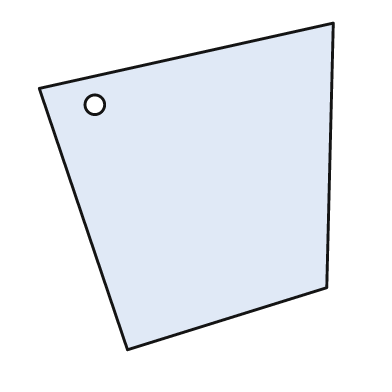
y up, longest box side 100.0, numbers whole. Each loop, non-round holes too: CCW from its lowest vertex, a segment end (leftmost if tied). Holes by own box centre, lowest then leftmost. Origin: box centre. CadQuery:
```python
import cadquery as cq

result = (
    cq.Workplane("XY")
    .moveTo(-18.0, -50.0)
    .lineTo(43.0, -31.0)
    .lineTo(45.0, 50.0)
    .lineTo(-45.0, 30.0)
    .close()
    .moveTo(-28.0, 25.0)
    .circle(3.0)
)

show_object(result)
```